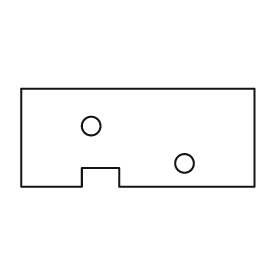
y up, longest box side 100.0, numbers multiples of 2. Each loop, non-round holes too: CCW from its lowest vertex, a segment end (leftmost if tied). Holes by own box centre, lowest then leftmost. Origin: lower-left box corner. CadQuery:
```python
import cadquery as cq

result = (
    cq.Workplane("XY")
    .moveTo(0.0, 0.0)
    .lineTo(26.0, 0.0)
    .lineTo(26.0, 8.0)
    .lineTo(42.0, 8.0)
    .lineTo(42.0, 0.0)
    .lineTo(100.0, 0.0)
    .lineTo(100.0, 42.0)
    .lineTo(0.0, 42.0)
    .close()
    .moveTo(70.0, 10.0)
    .circle(4.0)
    .moveTo(30.0, 26.0)
    .circle(4.0)
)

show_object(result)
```